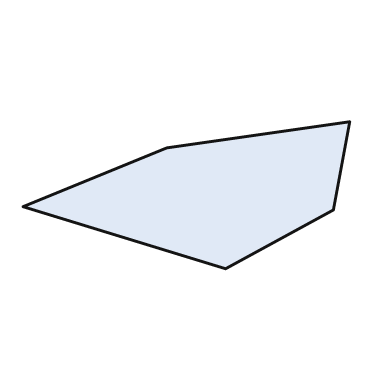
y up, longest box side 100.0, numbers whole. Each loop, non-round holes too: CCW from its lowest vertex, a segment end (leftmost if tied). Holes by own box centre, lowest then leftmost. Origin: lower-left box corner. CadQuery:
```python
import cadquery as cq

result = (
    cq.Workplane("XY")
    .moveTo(62.0, 0.0)
    .lineTo(95.0, 18.0)
    .lineTo(100.0, 45.0)
    .lineTo(44.0, 37.0)
    .lineTo(0.0, 19.0)
    .close()
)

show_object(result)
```